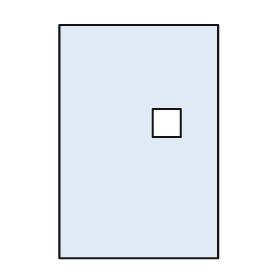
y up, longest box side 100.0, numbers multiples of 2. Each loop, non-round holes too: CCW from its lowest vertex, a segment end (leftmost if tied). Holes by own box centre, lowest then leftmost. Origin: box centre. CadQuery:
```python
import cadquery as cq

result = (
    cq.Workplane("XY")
    .moveTo(-34.0, -50.0)
    .lineTo(34.0, -50.0)
    .lineTo(34.0, 50.0)
    .lineTo(-34.0, 50.0)
    .close()
    .moveTo(6.0, 2.0)
    .lineTo(18.0, 2.0)
    .lineTo(18.0, 14.0)
    .lineTo(6.0, 14.0)
    .close()
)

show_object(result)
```